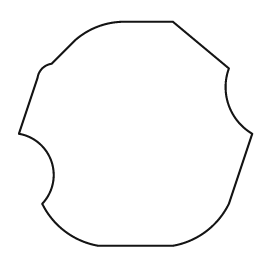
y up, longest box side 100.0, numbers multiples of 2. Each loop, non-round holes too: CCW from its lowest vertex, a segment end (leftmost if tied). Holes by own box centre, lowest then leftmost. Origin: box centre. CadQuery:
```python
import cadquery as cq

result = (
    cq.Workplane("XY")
    .moveTo(-16.0, -48.0)
    .lineTo(16.0, -48.0)
    .threePointArc((30.0, -42.0), (40.0, -30.0))
    .lineTo(50.0, 0.0)
    .threePointArc((40.0, 12.0), (40.0, 28.0))
    .lineTo(16.0, 48.0)
    .lineTo(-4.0, 48.0)
    .threePointArc((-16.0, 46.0), (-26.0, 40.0))
    .lineTo(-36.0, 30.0)
    .threePointArc((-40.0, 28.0), (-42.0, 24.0))
    .lineTo(-50.0, 0.0)
    .threePointArc((-36.0, -12.0), (-40.0, -30.0))
    .threePointArc((-30.0, -42.0), (-16.0, -48.0))
    .close()
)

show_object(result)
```